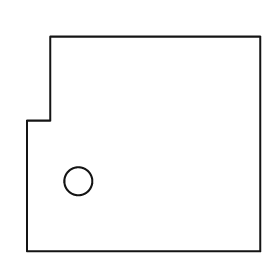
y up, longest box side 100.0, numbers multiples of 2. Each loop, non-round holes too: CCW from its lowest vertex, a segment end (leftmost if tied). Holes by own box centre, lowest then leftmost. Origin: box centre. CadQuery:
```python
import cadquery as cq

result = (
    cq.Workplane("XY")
    .moveTo(-50.0, -46.0)
    .lineTo(50.0, -46.0)
    .lineTo(50.0, 46.0)
    .lineTo(-40.0, 46.0)
    .lineTo(-40.0, 10.0)
    .lineTo(-50.0, 10.0)
    .close()
    .moveTo(-28.0, -16.0)
    .circle(6.0)
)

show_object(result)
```